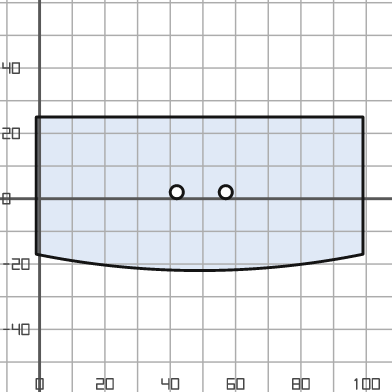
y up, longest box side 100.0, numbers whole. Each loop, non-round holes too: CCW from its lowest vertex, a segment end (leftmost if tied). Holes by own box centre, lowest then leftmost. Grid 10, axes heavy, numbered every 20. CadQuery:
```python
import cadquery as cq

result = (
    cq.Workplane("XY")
    .moveTo(-1.0, -17.0)
    .threePointArc((49.0, -22.0), (99.0, -17.0))
    .lineTo(99.0, 25.0)
    .lineTo(-1.0, 25.0)
    .close()
    .moveTo(42.0, 2.0)
    .circle(2.0)
    .moveTo(57.0, 2.0)
    .circle(2.0)
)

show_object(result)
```